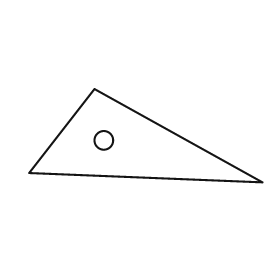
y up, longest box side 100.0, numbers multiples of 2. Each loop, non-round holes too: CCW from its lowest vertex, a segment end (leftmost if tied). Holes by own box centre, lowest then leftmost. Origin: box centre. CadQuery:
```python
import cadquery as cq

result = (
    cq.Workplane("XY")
    .moveTo(50.0, -20.0)
    .lineTo(-22.0, 20.0)
    .lineTo(-50.0, -16.0)
    .close()
    .moveTo(-18.0, -2.0)
    .circle(4.0)
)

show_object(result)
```